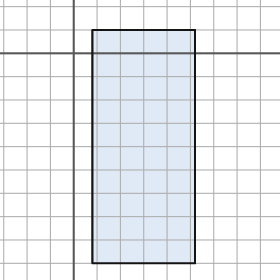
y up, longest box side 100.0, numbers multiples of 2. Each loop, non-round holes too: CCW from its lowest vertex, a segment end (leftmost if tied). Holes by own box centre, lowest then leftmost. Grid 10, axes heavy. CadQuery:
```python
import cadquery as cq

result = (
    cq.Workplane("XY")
    .moveTo(8.0, -90.0)
    .lineTo(52.0, -90.0)
    .lineTo(52.0, 10.0)
    .lineTo(8.0, 10.0)
    .close()
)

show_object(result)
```